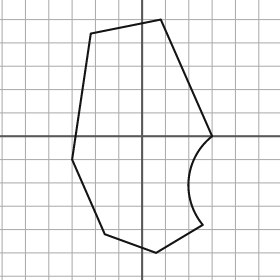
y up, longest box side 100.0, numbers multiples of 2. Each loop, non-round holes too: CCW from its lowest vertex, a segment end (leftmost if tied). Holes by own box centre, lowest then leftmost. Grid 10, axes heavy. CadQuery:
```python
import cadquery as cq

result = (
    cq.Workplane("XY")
    .moveTo(6.0, -50.0)
    .lineTo(26.0, -38.0)
    .threePointArc((20.0, -18.0), (30.0, 0.0))
    .lineTo(8.0, 50.0)
    .lineTo(-22.0, 44.0)
    .lineTo(-30.0, -10.0)
    .lineTo(-16.0, -42.0)
    .close()
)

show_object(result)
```